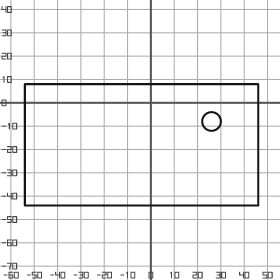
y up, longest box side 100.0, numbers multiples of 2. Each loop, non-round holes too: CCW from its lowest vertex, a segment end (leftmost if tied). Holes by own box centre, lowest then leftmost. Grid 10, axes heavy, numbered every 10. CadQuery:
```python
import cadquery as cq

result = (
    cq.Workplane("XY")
    .moveTo(-54.0, -44.0)
    .lineTo(46.0, -44.0)
    .lineTo(46.0, 8.0)
    .lineTo(-54.0, 8.0)
    .close()
    .moveTo(26.0, -8.0)
    .circle(4.0)
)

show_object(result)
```